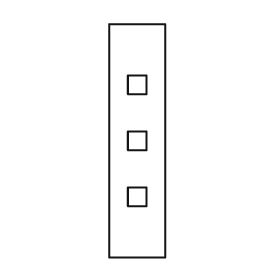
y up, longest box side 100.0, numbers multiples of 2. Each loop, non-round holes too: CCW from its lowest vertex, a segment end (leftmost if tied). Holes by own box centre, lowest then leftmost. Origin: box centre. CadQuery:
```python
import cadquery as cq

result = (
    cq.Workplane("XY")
    .moveTo(-12.0, -50.0)
    .lineTo(12.0, -50.0)
    .lineTo(12.0, 50.0)
    .lineTo(-12.0, 50.0)
    .close()
    .moveTo(-4.0, -28.0)
    .lineTo(4.0, -28.0)
    .lineTo(4.0, -20.0)
    .lineTo(-4.0, -20.0)
    .close()
    .moveTo(-4.0, -4.0)
    .lineTo(4.0, -4.0)
    .lineTo(4.0, 4.0)
    .lineTo(-4.0, 4.0)
    .close()
    .moveTo(-4.0, 20.0)
    .lineTo(4.0, 20.0)
    .lineTo(4.0, 28.0)
    .lineTo(-4.0, 28.0)
    .close()
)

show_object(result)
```